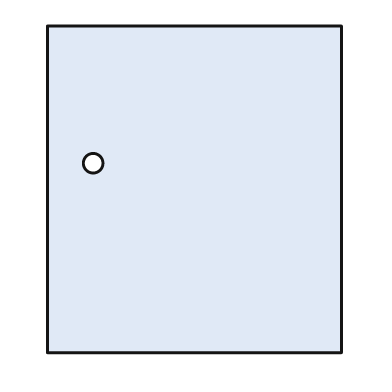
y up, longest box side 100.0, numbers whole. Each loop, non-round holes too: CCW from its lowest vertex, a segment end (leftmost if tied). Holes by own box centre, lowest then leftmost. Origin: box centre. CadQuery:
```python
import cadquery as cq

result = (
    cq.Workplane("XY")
    .moveTo(-45.0, -50.0)
    .lineTo(45.0, -50.0)
    .lineTo(45.0, 50.0)
    .lineTo(-45.0, 50.0)
    .close()
    .moveTo(-31.0, 8.0)
    .circle(3.0)
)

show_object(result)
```